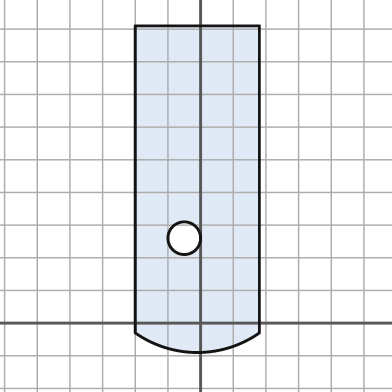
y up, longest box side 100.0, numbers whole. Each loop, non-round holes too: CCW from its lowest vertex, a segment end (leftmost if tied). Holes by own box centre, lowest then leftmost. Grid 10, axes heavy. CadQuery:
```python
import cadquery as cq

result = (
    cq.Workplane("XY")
    .moveTo(-20.0, -3.0)
    .threePointArc((-1.0, -9.0), (18.0, -3.0))
    .lineTo(18.0, 91.0)
    .lineTo(-20.0, 91.0)
    .close()
    .moveTo(-5.0, 26.0)
    .circle(5.0)
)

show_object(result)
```